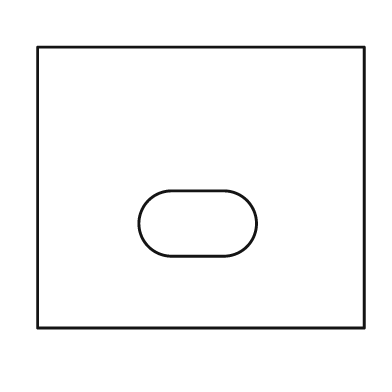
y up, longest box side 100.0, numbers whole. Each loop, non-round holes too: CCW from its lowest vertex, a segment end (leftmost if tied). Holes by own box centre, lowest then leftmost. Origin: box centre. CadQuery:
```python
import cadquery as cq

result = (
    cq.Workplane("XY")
    .moveTo(-50.0, -43.0)
    .lineTo(50.0, -43.0)
    .lineTo(50.0, 43.0)
    .lineTo(-50.0, 43.0)
    .close()
    .moveTo(-9.0, -21.0)
    .lineTo(7.0, -21.0)
    .threePointArc((17.0, -11.0), (7.0, -1.0))
    .lineTo(-9.0, -1.0)
    .threePointArc((-19.0, -11.0), (-9.0, -21.0))
    .close()
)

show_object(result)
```